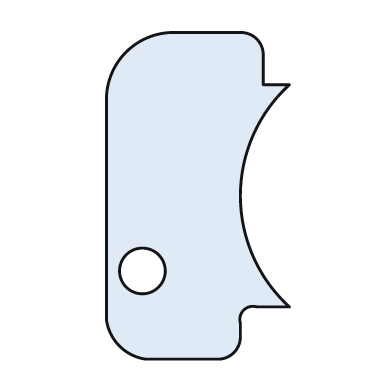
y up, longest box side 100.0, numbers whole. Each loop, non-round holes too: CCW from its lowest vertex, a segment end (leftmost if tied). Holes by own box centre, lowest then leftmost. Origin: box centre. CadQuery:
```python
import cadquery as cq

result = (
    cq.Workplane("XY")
    .moveTo(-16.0, -50.0)
    .lineTo(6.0, -50.0)
    .threePointArc((11.0, -48.0), (13.0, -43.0))
    .lineTo(13.0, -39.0)
    .threePointArc((14.0, -35.0), (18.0, -34.0))
    .lineTo(28.0, -34.0)
    .threePointArc((13.0, 0.0), (28.0, 34.0))
    .lineTo(20.0, 34.0)
    .lineTo(20.0, 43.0)
    .threePointArc((18.0, 48.0), (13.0, 50.0))
    .lineTo(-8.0, 50.0)
    .threePointArc((-22.0, 44.0), (-28.0, 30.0))
    .lineTo(-28.0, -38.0)
    .threePointArc((-24.0, -46.0), (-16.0, -50.0))
    .close()
    .moveTo(-17.0, -23.0)
    .circle(7.0)
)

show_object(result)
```